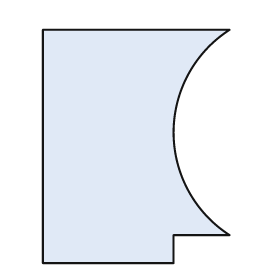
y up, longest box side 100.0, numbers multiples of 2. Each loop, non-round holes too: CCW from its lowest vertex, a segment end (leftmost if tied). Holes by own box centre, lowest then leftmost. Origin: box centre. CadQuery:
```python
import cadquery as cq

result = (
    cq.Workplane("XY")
    .moveTo(-40.0, -50.0)
    .lineTo(16.0, -50.0)
    .lineTo(16.0, -38.0)
    .lineTo(40.0, -38.0)
    .threePointArc((16.0, 6.0), (40.0, 50.0))
    .lineTo(-40.0, 50.0)
    .close()
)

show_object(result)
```